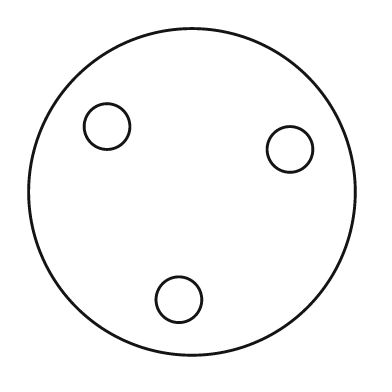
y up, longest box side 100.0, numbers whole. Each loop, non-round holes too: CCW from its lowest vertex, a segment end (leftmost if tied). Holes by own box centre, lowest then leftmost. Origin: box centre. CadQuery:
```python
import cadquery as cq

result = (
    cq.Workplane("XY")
    .moveTo(0.0, 0.0)
    .circle(50.0)
    .moveTo(-4.0, -33.0)
    .circle(7.0)
    .moveTo(30.0, 13.0)
    .circle(7.0)
    .moveTo(-26.0, 20.0)
    .circle(7.0)
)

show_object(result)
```